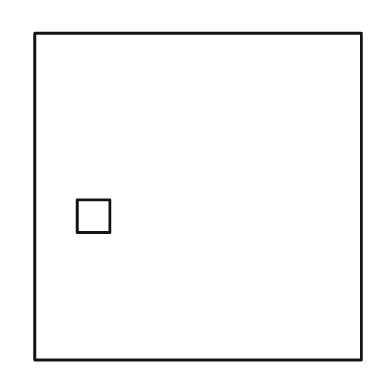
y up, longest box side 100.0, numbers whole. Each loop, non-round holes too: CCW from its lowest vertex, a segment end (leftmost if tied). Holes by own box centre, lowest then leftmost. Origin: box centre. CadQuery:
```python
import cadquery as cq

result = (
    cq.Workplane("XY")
    .moveTo(-50.0, -50.0)
    .lineTo(50.0, -50.0)
    .lineTo(50.0, 50.0)
    .lineTo(-50.0, 50.0)
    .close()
    .moveTo(-37.0, -11.0)
    .lineTo(-27.0, -11.0)
    .lineTo(-27.0, -1.0)
    .lineTo(-37.0, -1.0)
    .close()
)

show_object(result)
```